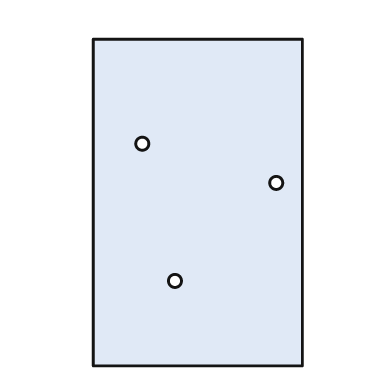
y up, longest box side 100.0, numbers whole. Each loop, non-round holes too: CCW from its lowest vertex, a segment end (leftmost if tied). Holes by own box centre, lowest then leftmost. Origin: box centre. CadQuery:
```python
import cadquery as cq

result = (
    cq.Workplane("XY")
    .moveTo(-32.0, -50.0)
    .lineTo(32.0, -50.0)
    .lineTo(32.0, 50.0)
    .lineTo(-32.0, 50.0)
    .close()
    .moveTo(-7.0, -24.0)
    .circle(2.0)
    .moveTo(24.0, 6.0)
    .circle(2.0)
    .moveTo(-17.0, 18.0)
    .circle(2.0)
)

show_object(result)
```